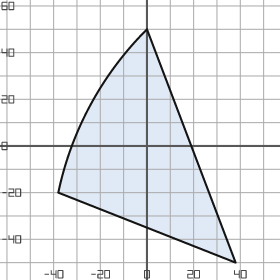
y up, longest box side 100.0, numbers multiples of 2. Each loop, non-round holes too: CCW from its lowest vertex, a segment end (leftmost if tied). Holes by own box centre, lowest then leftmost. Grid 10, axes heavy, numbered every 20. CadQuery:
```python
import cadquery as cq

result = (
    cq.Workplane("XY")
    .moveTo(38.0, -50.0)
    .lineTo(0.0, 50.0)
    .threePointArc((-24.0, 18.0), (-38.0, -20.0))
    .close()
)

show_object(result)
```